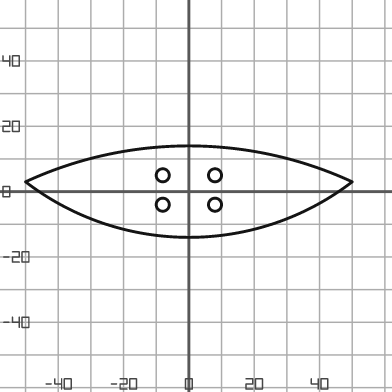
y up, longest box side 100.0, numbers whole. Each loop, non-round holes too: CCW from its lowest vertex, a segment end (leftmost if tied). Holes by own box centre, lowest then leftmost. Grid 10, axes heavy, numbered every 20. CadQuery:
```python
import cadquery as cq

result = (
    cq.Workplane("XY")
    .moveTo(-50.0, 3.0)
    .threePointArc((0.0, -14.0), (50.0, 3.0))
    .threePointArc((0.0, 14.0), (-50.0, 3.0))
    .close()
    .moveTo(-8.0, -4.0)
    .circle(2.0)
    .moveTo(8.0, -4.0)
    .circle(2.0)
    .moveTo(-8.0, 5.0)
    .circle(2.0)
    .moveTo(8.0, 5.0)
    .circle(2.0)
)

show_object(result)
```